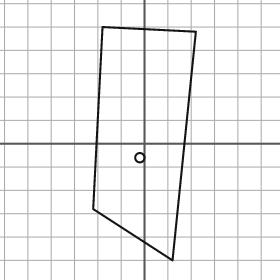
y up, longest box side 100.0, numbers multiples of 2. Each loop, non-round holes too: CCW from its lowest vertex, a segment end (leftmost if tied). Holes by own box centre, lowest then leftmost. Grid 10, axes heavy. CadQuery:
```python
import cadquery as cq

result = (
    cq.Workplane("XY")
    .moveTo(12.0, -50.0)
    .lineTo(22.0, 48.0)
    .lineTo(-18.0, 50.0)
    .lineTo(-22.0, -28.0)
    .close()
    .moveTo(-2.0, -6.0)
    .circle(2.0)
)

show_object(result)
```